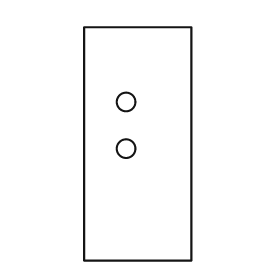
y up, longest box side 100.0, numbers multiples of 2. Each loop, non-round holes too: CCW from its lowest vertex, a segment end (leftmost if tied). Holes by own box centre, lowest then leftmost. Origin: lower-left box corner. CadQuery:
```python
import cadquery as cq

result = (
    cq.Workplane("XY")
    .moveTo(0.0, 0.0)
    .lineTo(46.0, 0.0)
    .lineTo(46.0, 100.0)
    .lineTo(0.0, 100.0)
    .close()
    .moveTo(18.0, 48.0)
    .circle(4.0)
    .moveTo(18.0, 68.0)
    .circle(4.0)
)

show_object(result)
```